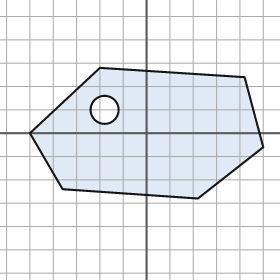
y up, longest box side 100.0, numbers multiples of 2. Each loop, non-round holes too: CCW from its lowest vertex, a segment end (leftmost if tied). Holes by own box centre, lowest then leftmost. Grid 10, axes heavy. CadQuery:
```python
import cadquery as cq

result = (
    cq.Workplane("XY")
    .moveTo(22.0, -28.0)
    .lineTo(50.0, -6.0)
    .lineTo(42.0, 24.0)
    .lineTo(-20.0, 28.0)
    .lineTo(-50.0, 0.0)
    .lineTo(-36.0, -24.0)
    .close()
    .moveTo(-18.0, 10.0)
    .circle(6.0)
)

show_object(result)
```